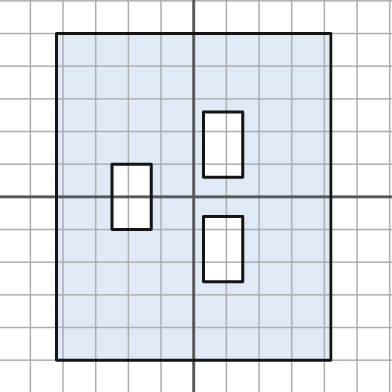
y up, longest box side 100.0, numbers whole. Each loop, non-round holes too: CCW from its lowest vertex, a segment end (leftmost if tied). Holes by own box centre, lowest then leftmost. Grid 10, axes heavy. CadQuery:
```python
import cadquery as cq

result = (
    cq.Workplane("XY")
    .moveTo(-42.0, -50.0)
    .lineTo(42.0, -50.0)
    .lineTo(42.0, 50.0)
    .lineTo(-42.0, 50.0)
    .close()
    .moveTo(3.0, -26.0)
    .lineTo(15.0, -26.0)
    .lineTo(15.0, -6.0)
    .lineTo(3.0, -6.0)
    .close()
    .moveTo(-25.0, -10.0)
    .lineTo(-13.0, -10.0)
    .lineTo(-13.0, 10.0)
    .lineTo(-25.0, 10.0)
    .close()
    .moveTo(3.0, 6.0)
    .lineTo(15.0, 6.0)
    .lineTo(15.0, 26.0)
    .lineTo(3.0, 26.0)
    .close()
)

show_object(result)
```